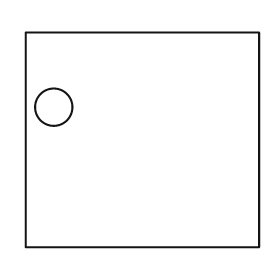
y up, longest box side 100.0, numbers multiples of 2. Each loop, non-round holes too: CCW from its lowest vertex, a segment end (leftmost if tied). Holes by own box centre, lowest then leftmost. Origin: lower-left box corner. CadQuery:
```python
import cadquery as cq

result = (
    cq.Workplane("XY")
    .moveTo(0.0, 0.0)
    .lineTo(100.0, 0.0)
    .lineTo(100.0, 92.0)
    .lineTo(0.0, 92.0)
    .close()
    .moveTo(12.0, 60.0)
    .circle(8.0)
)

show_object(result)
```